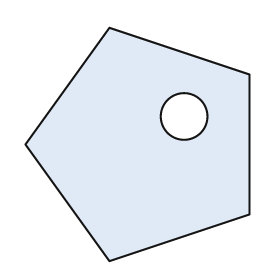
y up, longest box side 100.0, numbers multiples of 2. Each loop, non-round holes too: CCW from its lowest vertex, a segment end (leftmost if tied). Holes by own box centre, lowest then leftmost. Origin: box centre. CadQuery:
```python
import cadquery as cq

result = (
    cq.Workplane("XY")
    .moveTo(-12.0, -50.0)
    .lineTo(48.0, -30.0)
    .lineTo(48.0, 30.0)
    .lineTo(-12.0, 50.0)
    .lineTo(-48.0, 0.0)
    .close()
    .moveTo(20.0, 12.0)
    .circle(10.0)
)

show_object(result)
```